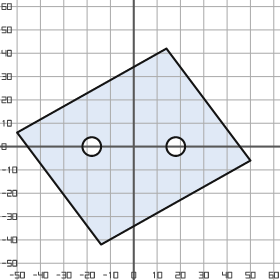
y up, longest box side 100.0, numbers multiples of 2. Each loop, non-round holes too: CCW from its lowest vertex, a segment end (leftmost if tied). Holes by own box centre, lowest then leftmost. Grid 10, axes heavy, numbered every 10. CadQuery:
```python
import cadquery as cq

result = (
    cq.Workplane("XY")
    .moveTo(-14.0, -42.0)
    .lineTo(50.0, -6.0)
    .lineTo(14.0, 42.0)
    .lineTo(-50.0, 6.0)
    .close()
    .moveTo(-18.0, 0.0)
    .circle(4.0)
    .moveTo(18.0, 0.0)
    .circle(4.0)
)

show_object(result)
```